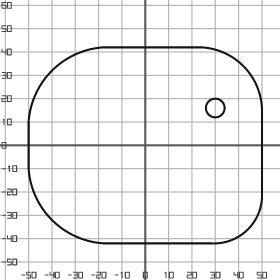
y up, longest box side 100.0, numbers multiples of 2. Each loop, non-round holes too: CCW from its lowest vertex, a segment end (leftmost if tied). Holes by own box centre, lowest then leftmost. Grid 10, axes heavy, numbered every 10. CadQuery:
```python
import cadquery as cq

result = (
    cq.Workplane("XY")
    .moveTo(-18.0, -42.0)
    .lineTo(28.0, -42.0)
    .threePointArc((44.0, -36.0), (50.0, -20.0))
    .lineTo(50.0, 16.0)
    .threePointArc((42.0, 34.0), (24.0, 42.0))
    .lineTo(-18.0, 42.0)
    .threePointArc((-40.0, 32.0), (-50.0, 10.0))
    .lineTo(-50.0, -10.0)
    .threePointArc((-40.0, -32.0), (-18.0, -42.0))
    .close()
    .moveTo(30.0, 16.0)
    .circle(4.0)
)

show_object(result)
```